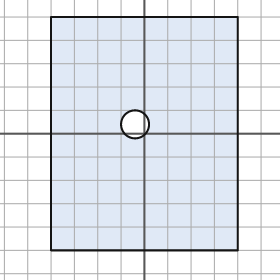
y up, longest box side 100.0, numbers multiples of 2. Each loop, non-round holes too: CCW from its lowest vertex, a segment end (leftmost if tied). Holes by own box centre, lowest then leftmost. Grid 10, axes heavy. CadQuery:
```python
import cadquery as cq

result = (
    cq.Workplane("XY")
    .moveTo(-40.0, -50.0)
    .lineTo(40.0, -50.0)
    .lineTo(40.0, 50.0)
    .lineTo(-40.0, 50.0)
    .close()
    .moveTo(-4.0, 4.0)
    .circle(6.0)
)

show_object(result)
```